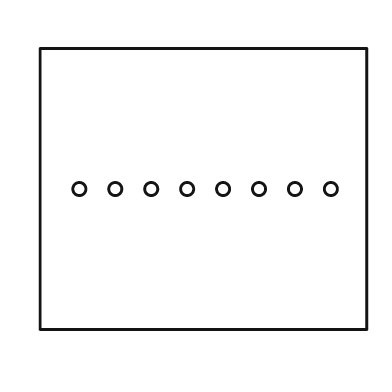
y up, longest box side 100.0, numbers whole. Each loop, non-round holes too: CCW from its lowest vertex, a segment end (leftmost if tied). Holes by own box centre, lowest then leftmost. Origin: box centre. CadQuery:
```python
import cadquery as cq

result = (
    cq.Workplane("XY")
    .moveTo(-50.0, -43.0)
    .lineTo(50.0, -43.0)
    .lineTo(50.0, 43.0)
    .lineTo(-50.0, 43.0)
    .close()
    .moveTo(-38.0, 0.0)
    .circle(2.0)
    .moveTo(-27.0, 0.0)
    .circle(2.0)
    .moveTo(-16.0, 0.0)
    .circle(2.0)
    .moveTo(-5.0, 0.0)
    .circle(2.0)
    .moveTo(6.0, 0.0)
    .circle(2.0)
    .moveTo(17.0, 0.0)
    .circle(2.0)
    .moveTo(28.0, 0.0)
    .circle(2.0)
    .moveTo(39.0, 0.0)
    .circle(2.0)
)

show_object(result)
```